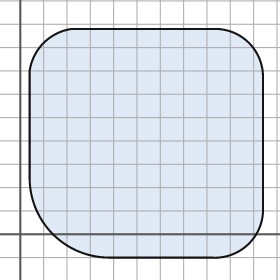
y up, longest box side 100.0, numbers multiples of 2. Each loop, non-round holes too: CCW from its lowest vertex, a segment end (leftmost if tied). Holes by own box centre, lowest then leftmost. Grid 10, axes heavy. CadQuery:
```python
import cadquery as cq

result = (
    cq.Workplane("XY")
    .moveTo(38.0, -10.0)
    .lineTo(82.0, -10.0)
    .threePointArc((98.0, -4.0), (104.0, 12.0))
    .lineTo(104.0, 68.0)
    .threePointArc((98.0, 82.0), (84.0, 88.0))
    .lineTo(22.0, 88.0)
    .threePointArc((10.0, 82.0), (4.0, 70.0))
    .lineTo(4.0, 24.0)
    .threePointArc((14.0, 0.0), (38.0, -10.0))
    .close()
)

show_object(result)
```